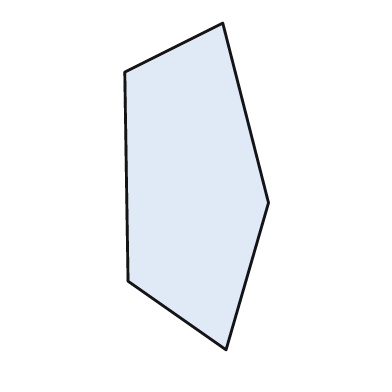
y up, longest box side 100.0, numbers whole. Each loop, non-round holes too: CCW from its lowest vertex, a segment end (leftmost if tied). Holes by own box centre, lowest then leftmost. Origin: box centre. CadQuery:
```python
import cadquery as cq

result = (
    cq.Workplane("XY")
    .moveTo(9.0, -50.0)
    .lineTo(22.0, -5.0)
    .lineTo(8.0, 50.0)
    .lineTo(-22.0, 35.0)
    .lineTo(-21.0, -29.0)
    .close()
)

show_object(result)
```